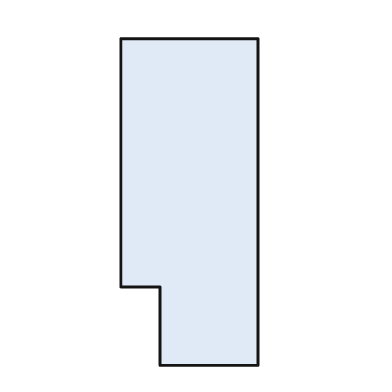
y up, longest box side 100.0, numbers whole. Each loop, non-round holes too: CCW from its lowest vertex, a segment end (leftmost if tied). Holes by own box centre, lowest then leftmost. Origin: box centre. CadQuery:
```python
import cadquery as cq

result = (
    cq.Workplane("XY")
    .moveTo(-9.0, -50.0)
    .lineTo(21.0, -50.0)
    .lineTo(21.0, 50.0)
    .lineTo(-21.0, 50.0)
    .lineTo(-21.0, -26.0)
    .lineTo(-9.0, -26.0)
    .close()
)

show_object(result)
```